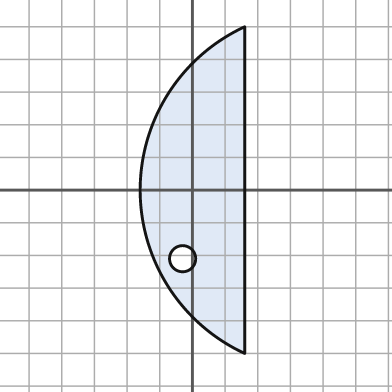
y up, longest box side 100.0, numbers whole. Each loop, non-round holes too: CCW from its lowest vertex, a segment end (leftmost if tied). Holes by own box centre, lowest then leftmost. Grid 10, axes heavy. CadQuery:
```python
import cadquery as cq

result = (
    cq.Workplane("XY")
    .moveTo(16.0, -50.0)
    .lineTo(16.0, 50.0)
    .threePointArc((-16.0, 0.0), (16.0, -50.0))
    .close()
    .moveTo(-3.0, -21.0)
    .circle(4.0)
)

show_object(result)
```